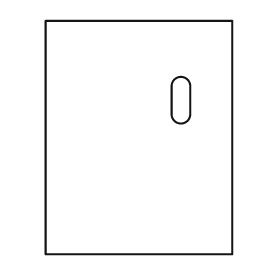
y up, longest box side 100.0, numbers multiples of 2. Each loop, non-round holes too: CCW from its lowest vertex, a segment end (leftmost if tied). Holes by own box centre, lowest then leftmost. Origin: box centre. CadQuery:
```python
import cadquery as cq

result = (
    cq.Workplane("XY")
    .moveTo(-40.0, -50.0)
    .lineTo(40.0, -50.0)
    .lineTo(40.0, 50.0)
    .lineTo(-40.0, 50.0)
    .close()
    .moveTo(14.0, 10.0)
    .threePointArc((18.0, 6.0), (22.0, 10.0))
    .lineTo(22.0, 22.0)
    .threePointArc((18.0, 26.0), (14.0, 22.0))
    .close()
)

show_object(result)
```